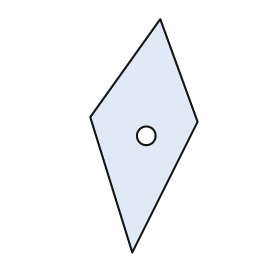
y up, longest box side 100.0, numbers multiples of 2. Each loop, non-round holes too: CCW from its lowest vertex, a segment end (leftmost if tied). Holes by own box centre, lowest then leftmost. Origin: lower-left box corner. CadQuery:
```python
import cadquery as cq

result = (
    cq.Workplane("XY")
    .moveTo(18.0, 0.0)
    .lineTo(46.0, 56.0)
    .lineTo(30.0, 100.0)
    .lineTo(0.0, 58.0)
    .close()
    .moveTo(24.0, 50.0)
    .circle(4.0)
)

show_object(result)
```